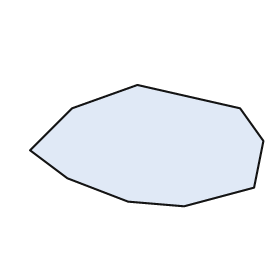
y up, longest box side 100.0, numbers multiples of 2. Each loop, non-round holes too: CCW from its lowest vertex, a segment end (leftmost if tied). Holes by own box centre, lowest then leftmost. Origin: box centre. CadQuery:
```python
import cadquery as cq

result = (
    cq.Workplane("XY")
    .moveTo(16.0, -26.0)
    .lineTo(46.0, -18.0)
    .lineTo(50.0, 2.0)
    .lineTo(40.0, 16.0)
    .lineTo(-4.0, 26.0)
    .lineTo(-32.0, 16.0)
    .lineTo(-50.0, -2.0)
    .lineTo(-34.0, -14.0)
    .lineTo(-8.0, -24.0)
    .close()
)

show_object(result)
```